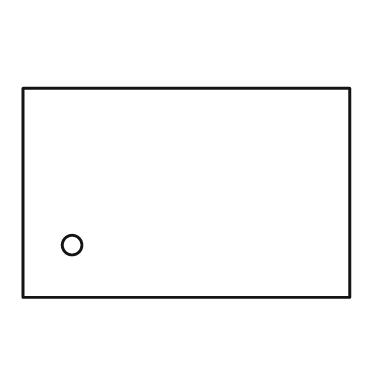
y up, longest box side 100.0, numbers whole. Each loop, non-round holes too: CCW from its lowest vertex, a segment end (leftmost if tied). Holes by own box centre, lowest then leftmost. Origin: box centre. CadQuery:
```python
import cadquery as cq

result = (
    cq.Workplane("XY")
    .moveTo(-50.0, -32.0)
    .lineTo(50.0, -32.0)
    .lineTo(50.0, 32.0)
    .lineTo(-50.0, 32.0)
    .close()
    .moveTo(-35.0, -16.0)
    .circle(3.0)
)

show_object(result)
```